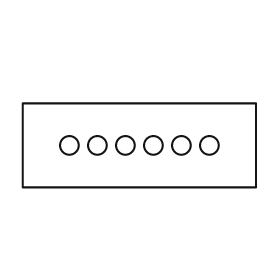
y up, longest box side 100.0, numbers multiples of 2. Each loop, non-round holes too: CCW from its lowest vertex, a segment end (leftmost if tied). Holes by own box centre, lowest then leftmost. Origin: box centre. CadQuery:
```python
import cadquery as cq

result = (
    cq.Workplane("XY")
    .moveTo(-50.0, -18.0)
    .lineTo(50.0, -18.0)
    .lineTo(50.0, 18.0)
    .lineTo(-50.0, 18.0)
    .close()
    .moveTo(-30.0, 0.0)
    .circle(4.0)
    .moveTo(-18.0, 0.0)
    .circle(4.0)
    .moveTo(-6.0, 0.0)
    .circle(4.0)
    .moveTo(6.0, 0.0)
    .circle(4.0)
    .moveTo(18.0, 0.0)
    .circle(4.0)
    .moveTo(30.0, 0.0)
    .circle(4.0)
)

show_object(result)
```